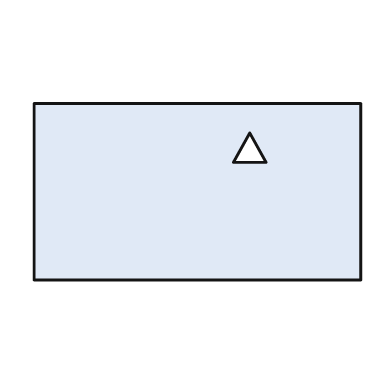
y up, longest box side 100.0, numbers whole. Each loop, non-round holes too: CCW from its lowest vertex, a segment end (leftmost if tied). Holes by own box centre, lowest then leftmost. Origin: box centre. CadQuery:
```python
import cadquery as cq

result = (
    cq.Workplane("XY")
    .moveTo(-50.0, -27.0)
    .lineTo(50.0, -27.0)
    .lineTo(50.0, 27.0)
    .lineTo(-50.0, 27.0)
    .close()
    .moveTo(11.0, 9.0)
    .lineTo(21.0, 9.0)
    .lineTo(16.0, 18.0)
    .close()
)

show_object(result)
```